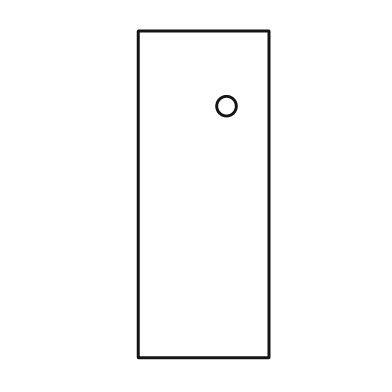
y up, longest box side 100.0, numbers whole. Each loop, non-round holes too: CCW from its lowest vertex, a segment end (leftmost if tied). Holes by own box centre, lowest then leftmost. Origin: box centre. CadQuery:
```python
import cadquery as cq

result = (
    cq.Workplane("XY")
    .moveTo(-20.0, -50.0)
    .lineTo(20.0, -50.0)
    .lineTo(20.0, 50.0)
    .lineTo(-20.0, 50.0)
    .close()
    .moveTo(7.0, 27.0)
    .circle(3.0)
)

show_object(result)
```